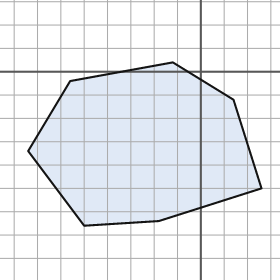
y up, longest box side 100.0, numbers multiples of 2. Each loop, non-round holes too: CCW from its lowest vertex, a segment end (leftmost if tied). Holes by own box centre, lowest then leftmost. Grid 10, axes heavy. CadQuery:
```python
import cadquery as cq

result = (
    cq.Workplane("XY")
    .moveTo(-50.0, -66.0)
    .lineTo(-18.0, -64.0)
    .lineTo(26.0, -50.0)
    .lineTo(14.0, -12.0)
    .lineTo(-12.0, 4.0)
    .lineTo(-56.0, -4.0)
    .lineTo(-74.0, -34.0)
    .close()
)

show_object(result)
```